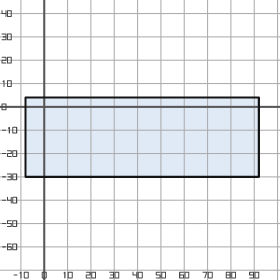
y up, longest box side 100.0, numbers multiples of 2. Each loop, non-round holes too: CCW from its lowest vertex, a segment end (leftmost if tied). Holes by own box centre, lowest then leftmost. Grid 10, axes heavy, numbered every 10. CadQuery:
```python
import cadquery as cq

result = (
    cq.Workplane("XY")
    .moveTo(-8.0, -30.0)
    .lineTo(92.0, -30.0)
    .lineTo(92.0, 4.0)
    .lineTo(-8.0, 4.0)
    .close()
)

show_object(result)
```